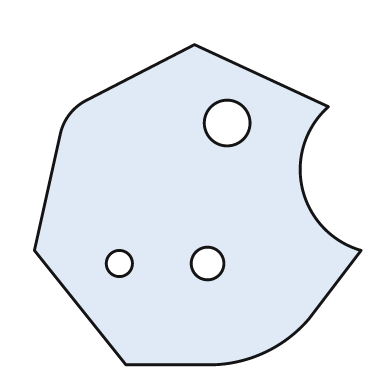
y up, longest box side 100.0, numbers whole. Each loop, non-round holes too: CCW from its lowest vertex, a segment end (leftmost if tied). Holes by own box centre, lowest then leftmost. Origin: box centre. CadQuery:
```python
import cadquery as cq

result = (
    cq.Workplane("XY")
    .moveTo(-22.0, -49.0)
    .lineTo(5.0, -49.0)
    .threePointArc((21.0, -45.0), (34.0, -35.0))
    .lineTo(50.0, -14.0)
    .threePointArc((32.0, 5.0), (40.0, 30.0))
    .lineTo(-1.0, 49.0)
    .lineTo(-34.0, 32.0)
    .threePointArc((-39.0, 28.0), (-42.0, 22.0))
    .lineTo(-50.0, -14.0)
    .close()
    .moveTo(-24.0, -18.0)
    .circle(4.0)
    .moveTo(3.0, -18.0)
    .circle(5.0)
    .moveTo(9.0, 25.0)
    .circle(7.0)
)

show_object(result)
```